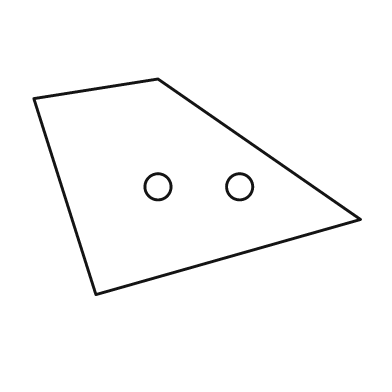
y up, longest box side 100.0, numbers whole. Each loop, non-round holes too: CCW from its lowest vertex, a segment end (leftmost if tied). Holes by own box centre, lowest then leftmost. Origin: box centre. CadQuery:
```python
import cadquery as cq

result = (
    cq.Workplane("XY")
    .moveTo(-31.0, -33.0)
    .lineTo(50.0, -10.0)
    .lineTo(-12.0, 33.0)
    .lineTo(-50.0, 27.0)
    .close()
    .moveTo(-12.0, 0.0)
    .circle(4.0)
    .moveTo(13.0, 0.0)
    .circle(4.0)
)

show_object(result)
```